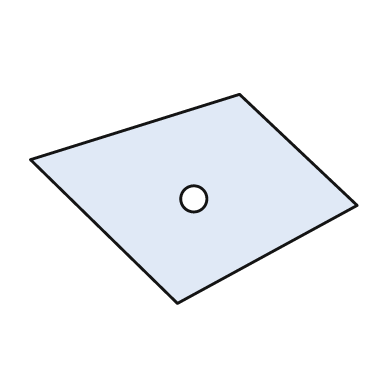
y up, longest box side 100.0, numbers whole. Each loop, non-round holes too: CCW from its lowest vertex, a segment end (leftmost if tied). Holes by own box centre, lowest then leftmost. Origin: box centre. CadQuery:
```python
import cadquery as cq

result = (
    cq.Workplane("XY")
    .moveTo(-5.0, -32.0)
    .lineTo(50.0, -2.0)
    .lineTo(14.0, 32.0)
    .lineTo(-50.0, 12.0)
    .close()
    .moveTo(0.0, 0.0)
    .circle(4.0)
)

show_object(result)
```